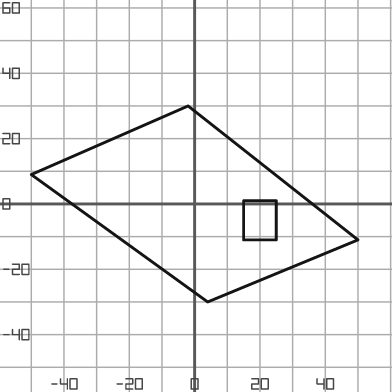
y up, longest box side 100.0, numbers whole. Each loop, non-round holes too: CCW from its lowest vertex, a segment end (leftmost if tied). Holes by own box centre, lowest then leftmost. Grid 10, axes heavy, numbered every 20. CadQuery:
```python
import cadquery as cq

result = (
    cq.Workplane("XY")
    .moveTo(4.0, -30.0)
    .lineTo(50.0, -11.0)
    .lineTo(-2.0, 30.0)
    .lineTo(-50.0, 9.0)
    .close()
    .moveTo(15.0, -11.0)
    .lineTo(25.0, -11.0)
    .lineTo(25.0, 1.0)
    .lineTo(15.0, 1.0)
    .close()
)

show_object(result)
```